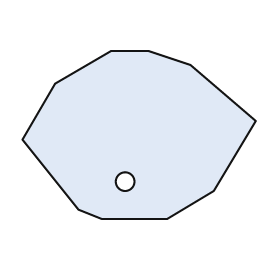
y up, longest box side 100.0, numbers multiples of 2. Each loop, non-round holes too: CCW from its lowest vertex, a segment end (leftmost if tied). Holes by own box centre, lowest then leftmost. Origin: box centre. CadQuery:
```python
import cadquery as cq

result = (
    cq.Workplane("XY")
    .moveTo(-16.0, -36.0)
    .lineTo(12.0, -36.0)
    .lineTo(32.0, -24.0)
    .lineTo(50.0, 6.0)
    .lineTo(22.0, 30.0)
    .lineTo(4.0, 36.0)
    .lineTo(-12.0, 36.0)
    .lineTo(-36.0, 22.0)
    .lineTo(-50.0, -2.0)
    .lineTo(-26.0, -32.0)
    .close()
    .moveTo(-6.0, -20.0)
    .circle(4.0)
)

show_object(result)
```